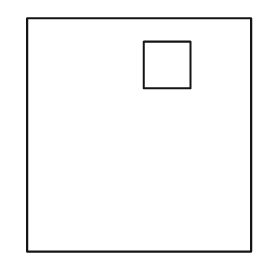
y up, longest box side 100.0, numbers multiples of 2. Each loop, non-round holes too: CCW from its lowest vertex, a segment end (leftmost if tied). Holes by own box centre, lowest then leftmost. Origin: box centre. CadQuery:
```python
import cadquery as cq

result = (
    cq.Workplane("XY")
    .moveTo(-48.0, -50.0)
    .lineTo(48.0, -50.0)
    .lineTo(48.0, 50.0)
    .lineTo(-48.0, 50.0)
    .close()
    .moveTo(2.0, 20.0)
    .lineTo(22.0, 20.0)
    .lineTo(22.0, 40.0)
    .lineTo(2.0, 40.0)
    .close()
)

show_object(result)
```